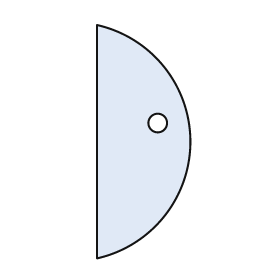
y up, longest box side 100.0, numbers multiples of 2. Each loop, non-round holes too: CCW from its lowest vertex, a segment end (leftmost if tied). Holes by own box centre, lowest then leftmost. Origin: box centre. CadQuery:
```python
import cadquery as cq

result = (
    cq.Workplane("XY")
    .moveTo(-20.0, -50.0)
    .threePointArc((20.0, 0.0), (-20.0, 50.0))
    .close()
    .moveTo(6.0, 8.0)
    .circle(4.0)
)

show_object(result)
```